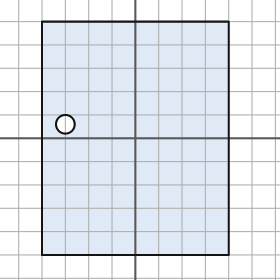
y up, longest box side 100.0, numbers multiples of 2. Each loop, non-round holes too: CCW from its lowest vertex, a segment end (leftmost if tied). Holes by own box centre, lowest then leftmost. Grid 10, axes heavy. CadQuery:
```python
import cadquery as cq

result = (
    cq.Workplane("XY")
    .moveTo(-40.0, -50.0)
    .lineTo(40.0, -50.0)
    .lineTo(40.0, 50.0)
    .lineTo(-40.0, 50.0)
    .close()
    .moveTo(-30.0, 6.0)
    .circle(4.0)
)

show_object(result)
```